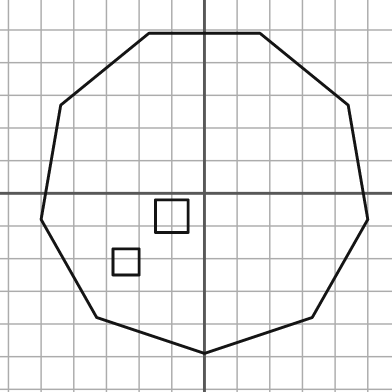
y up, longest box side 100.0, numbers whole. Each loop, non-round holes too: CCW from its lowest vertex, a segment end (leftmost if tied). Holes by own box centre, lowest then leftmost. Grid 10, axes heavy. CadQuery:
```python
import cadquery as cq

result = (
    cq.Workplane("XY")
    .moveTo(0.0, -49.0)
    .lineTo(33.0, -38.0)
    .lineTo(50.0, -8.0)
    .lineTo(44.0, 27.0)
    .lineTo(17.0, 49.0)
    .lineTo(-17.0, 49.0)
    .lineTo(-44.0, 27.0)
    .lineTo(-50.0, -8.0)
    .lineTo(-33.0, -38.0)
    .close()
    .moveTo(-28.0, -25.0)
    .lineTo(-20.0, -25.0)
    .lineTo(-20.0, -17.0)
    .lineTo(-28.0, -17.0)
    .close()
    .moveTo(-15.0, -12.0)
    .lineTo(-5.0, -12.0)
    .lineTo(-5.0, -2.0)
    .lineTo(-15.0, -2.0)
    .close()
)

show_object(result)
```